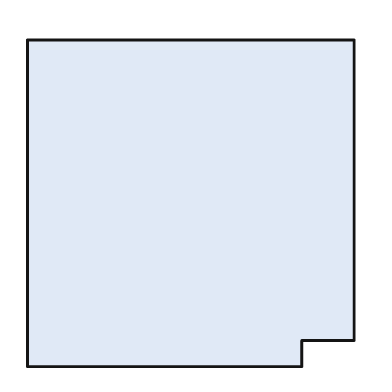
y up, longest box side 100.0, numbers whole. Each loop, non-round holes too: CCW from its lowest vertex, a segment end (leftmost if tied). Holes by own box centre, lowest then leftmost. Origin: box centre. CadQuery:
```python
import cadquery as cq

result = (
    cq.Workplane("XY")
    .moveTo(-50.0, -50.0)
    .lineTo(34.0, -50.0)
    .lineTo(34.0, -42.0)
    .lineTo(50.0, -42.0)
    .lineTo(50.0, 50.0)
    .lineTo(-50.0, 50.0)
    .close()
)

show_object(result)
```